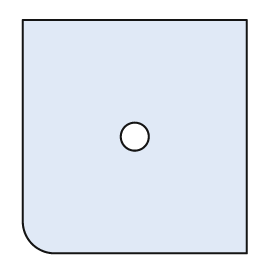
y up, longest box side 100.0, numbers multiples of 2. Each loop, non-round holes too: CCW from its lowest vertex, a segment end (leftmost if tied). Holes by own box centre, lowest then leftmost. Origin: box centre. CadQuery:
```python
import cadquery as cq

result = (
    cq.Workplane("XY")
    .moveTo(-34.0, -50.0)
    .lineTo(48.0, -50.0)
    .lineTo(48.0, 50.0)
    .lineTo(-48.0, 50.0)
    .lineTo(-48.0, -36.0)
    .threePointArc((-44.0, -46.0), (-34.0, -50.0))
    .close()
    .moveTo(0.0, 0.0)
    .circle(6.0)
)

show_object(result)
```